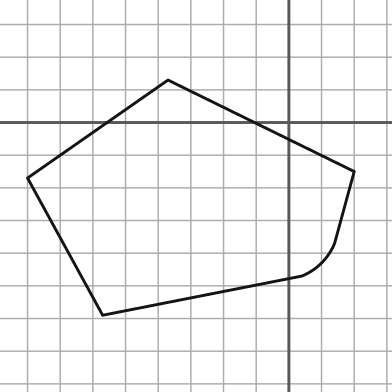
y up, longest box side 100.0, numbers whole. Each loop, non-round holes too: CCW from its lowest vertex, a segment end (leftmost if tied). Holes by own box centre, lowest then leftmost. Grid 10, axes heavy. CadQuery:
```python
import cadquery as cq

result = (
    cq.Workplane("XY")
    .moveTo(-57.0, -59.0)
    .lineTo(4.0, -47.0)
    .threePointArc((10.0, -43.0), (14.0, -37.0))
    .lineTo(20.0, -15.0)
    .lineTo(-37.0, 13.0)
    .lineTo(-80.0, -17.0)
    .close()
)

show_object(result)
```